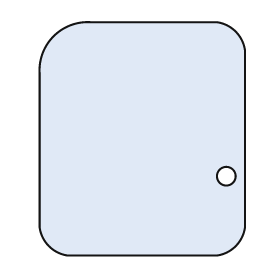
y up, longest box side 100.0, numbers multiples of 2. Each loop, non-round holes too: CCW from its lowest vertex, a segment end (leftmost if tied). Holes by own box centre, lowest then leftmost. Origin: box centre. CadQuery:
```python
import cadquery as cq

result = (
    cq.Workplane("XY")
    .moveTo(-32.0, -50.0)
    .lineTo(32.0, -50.0)
    .threePointArc((40.0, -46.0), (44.0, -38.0))
    .lineTo(44.0, 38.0)
    .threePointArc((40.0, 46.0), (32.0, 50.0))
    .lineTo(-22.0, 50.0)
    .threePointArc((-38.0, 44.0), (-44.0, 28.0))
    .lineTo(-44.0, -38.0)
    .threePointArc((-40.0, -46.0), (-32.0, -50.0))
    .close()
    .moveTo(36.0, -16.0)
    .circle(4.0)
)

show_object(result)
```